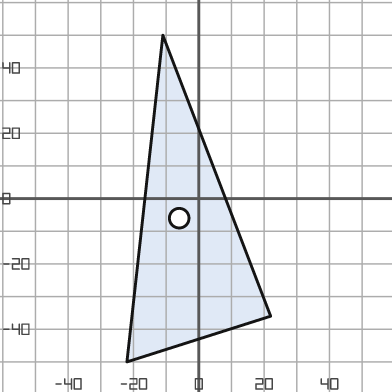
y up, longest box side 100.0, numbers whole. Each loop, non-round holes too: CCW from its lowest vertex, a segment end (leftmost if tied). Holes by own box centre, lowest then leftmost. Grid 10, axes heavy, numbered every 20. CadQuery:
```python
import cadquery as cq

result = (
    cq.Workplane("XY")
    .moveTo(-22.0, -50.0)
    .lineTo(22.0, -36.0)
    .lineTo(-11.0, 50.0)
    .close()
    .moveTo(-6.0, -6.0)
    .circle(3.0)
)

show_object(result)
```